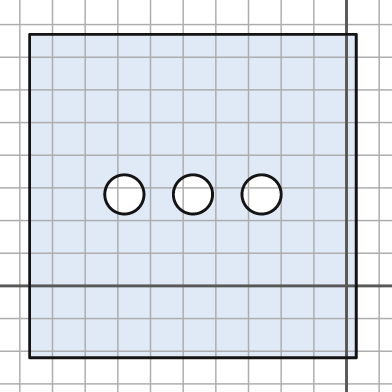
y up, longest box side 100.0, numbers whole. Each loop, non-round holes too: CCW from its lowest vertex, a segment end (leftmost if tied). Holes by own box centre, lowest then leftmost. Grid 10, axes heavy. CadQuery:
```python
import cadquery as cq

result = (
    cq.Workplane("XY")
    .moveTo(-97.0, -22.0)
    .lineTo(3.0, -22.0)
    .lineTo(3.0, 77.0)
    .lineTo(-97.0, 77.0)
    .close()
    .moveTo(-68.0, 28.0)
    .circle(6.0)
    .moveTo(-47.0, 28.0)
    .circle(6.0)
    .moveTo(-26.0, 28.0)
    .circle(6.0)
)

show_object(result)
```